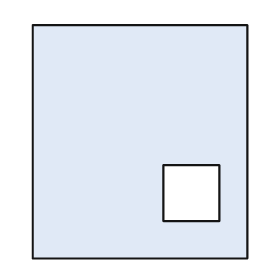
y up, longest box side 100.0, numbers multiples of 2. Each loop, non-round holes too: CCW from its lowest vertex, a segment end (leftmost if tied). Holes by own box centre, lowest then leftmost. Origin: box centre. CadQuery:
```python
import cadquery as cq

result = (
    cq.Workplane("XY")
    .moveTo(-46.0, -50.0)
    .lineTo(46.0, -50.0)
    .lineTo(46.0, 50.0)
    .lineTo(-46.0, 50.0)
    .close()
    .moveTo(10.0, -34.0)
    .lineTo(34.0, -34.0)
    .lineTo(34.0, -10.0)
    .lineTo(10.0, -10.0)
    .close()
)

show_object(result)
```